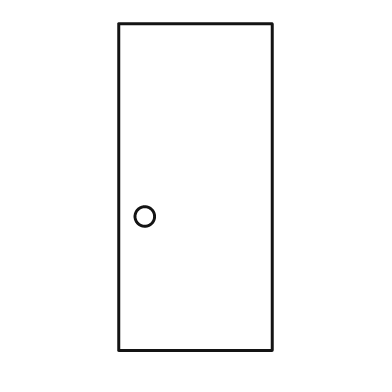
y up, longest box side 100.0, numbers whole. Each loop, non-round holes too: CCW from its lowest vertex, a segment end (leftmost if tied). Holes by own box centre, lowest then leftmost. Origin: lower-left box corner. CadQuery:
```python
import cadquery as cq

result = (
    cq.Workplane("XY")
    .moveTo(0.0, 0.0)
    .lineTo(47.0, 0.0)
    .lineTo(47.0, 100.0)
    .lineTo(0.0, 100.0)
    .close()
    .moveTo(8.0, 41.0)
    .circle(3.0)
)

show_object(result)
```